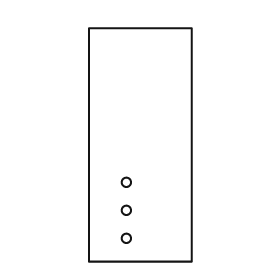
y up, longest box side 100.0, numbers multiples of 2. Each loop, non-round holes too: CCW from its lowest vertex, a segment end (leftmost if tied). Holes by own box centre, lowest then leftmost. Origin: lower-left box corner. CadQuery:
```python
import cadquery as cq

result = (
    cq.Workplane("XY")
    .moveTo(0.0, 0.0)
    .lineTo(44.0, 0.0)
    .lineTo(44.0, 100.0)
    .lineTo(0.0, 100.0)
    .close()
    .moveTo(16.0, 10.0)
    .circle(2.0)
    .moveTo(16.0, 22.0)
    .circle(2.0)
    .moveTo(16.0, 34.0)
    .circle(2.0)
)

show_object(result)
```